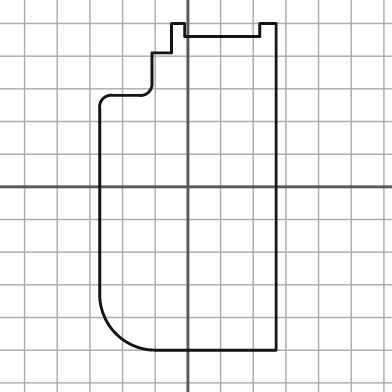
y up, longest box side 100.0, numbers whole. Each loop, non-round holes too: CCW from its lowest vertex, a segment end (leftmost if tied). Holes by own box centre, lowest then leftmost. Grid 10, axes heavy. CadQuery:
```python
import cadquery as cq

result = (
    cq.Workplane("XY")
    .moveTo(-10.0, -50.0)
    .lineTo(27.0, -50.0)
    .lineTo(27.0, 50.0)
    .lineTo(22.0, 50.0)
    .lineTo(22.0, 46.0)
    .lineTo(-1.0, 46.0)
    .lineTo(-1.0, 50.0)
    .lineTo(-5.0, 50.0)
    .lineTo(-5.0, 41.0)
    .lineTo(-11.0, 41.0)
    .lineTo(-11.0, 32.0)
    .threePointArc((-12.0, 29.0), (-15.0, 28.0))
    .lineTo(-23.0, 28.0)
    .threePointArc((-26.0, 27.0), (-27.0, 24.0))
    .lineTo(-27.0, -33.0)
    .threePointArc((-22.0, -45.0), (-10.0, -50.0))
    .close()
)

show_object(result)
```